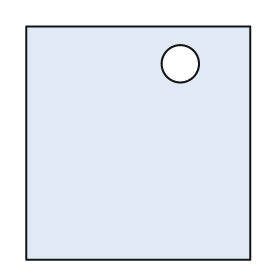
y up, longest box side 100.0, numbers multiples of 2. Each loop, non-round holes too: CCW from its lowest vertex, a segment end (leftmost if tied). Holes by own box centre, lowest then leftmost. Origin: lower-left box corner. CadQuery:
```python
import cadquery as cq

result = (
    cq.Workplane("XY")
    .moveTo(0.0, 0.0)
    .lineTo(96.0, 0.0)
    .lineTo(96.0, 100.0)
    .lineTo(0.0, 100.0)
    .close()
    .moveTo(66.0, 84.0)
    .circle(8.0)
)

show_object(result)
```